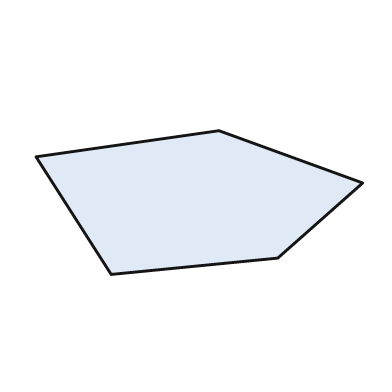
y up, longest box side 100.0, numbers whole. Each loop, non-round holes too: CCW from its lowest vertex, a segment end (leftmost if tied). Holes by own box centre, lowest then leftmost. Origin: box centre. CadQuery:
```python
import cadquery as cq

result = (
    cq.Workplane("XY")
    .moveTo(-27.0, -22.0)
    .lineTo(24.0, -17.0)
    .lineTo(50.0, 6.0)
    .lineTo(6.0, 22.0)
    .lineTo(-50.0, 14.0)
    .close()
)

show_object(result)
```